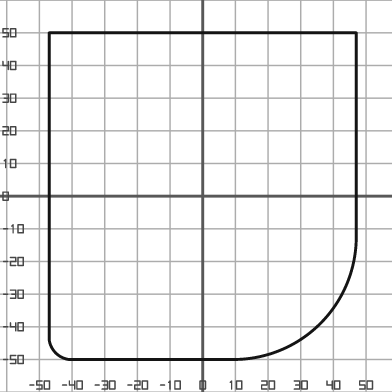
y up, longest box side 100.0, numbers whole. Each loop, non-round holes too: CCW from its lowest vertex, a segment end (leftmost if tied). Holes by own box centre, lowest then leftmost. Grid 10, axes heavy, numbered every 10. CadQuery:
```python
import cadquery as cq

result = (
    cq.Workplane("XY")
    .moveTo(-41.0, -50.0)
    .lineTo(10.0, -50.0)
    .threePointArc((36.0, -39.0), (47.0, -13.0))
    .lineTo(47.0, 50.0)
    .lineTo(-47.0, 50.0)
    .lineTo(-47.0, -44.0)
    .threePointArc((-45.0, -48.0), (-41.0, -50.0))
    .close()
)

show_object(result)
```